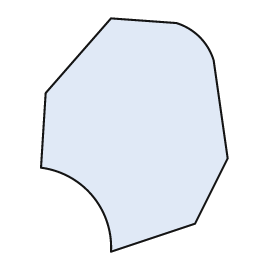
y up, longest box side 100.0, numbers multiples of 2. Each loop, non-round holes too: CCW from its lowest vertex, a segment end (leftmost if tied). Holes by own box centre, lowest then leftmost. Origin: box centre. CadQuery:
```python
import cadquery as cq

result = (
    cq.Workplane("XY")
    .moveTo(-10.0, -50.0)
    .lineTo(26.0, -38.0)
    .lineTo(40.0, -10.0)
    .lineTo(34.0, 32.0)
    .threePointArc((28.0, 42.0), (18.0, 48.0))
    .lineTo(-10.0, 50.0)
    .lineTo(-38.0, 18.0)
    .lineTo(-40.0, -14.0)
    .threePointArc((-18.0, -26.0), (-10.0, -50.0))
    .close()
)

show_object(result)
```